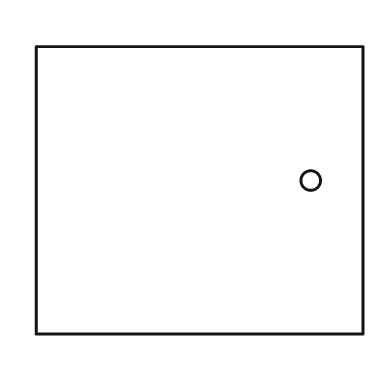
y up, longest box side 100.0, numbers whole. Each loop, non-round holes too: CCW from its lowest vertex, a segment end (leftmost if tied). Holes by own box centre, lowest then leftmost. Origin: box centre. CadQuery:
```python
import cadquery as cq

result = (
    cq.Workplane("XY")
    .moveTo(-50.0, -44.0)
    .lineTo(50.0, -44.0)
    .lineTo(50.0, 44.0)
    .lineTo(-50.0, 44.0)
    .close()
    .moveTo(34.0, 3.0)
    .circle(3.0)
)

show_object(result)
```